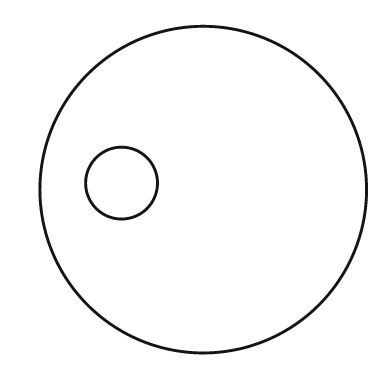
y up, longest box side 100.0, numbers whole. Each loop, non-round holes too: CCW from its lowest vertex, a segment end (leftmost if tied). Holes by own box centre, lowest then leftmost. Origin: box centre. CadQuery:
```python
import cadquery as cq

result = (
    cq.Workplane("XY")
    .moveTo(0.0, 0.0)
    .circle(50.0)
    .moveTo(-25.0, 2.0)
    .circle(11.0)
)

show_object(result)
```